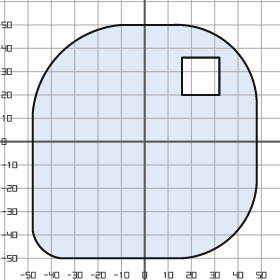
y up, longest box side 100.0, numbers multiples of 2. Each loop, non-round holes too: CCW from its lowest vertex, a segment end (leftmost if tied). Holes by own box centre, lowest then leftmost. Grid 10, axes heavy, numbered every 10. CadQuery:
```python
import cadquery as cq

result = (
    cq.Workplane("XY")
    .moveTo(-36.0, -50.0)
    .lineTo(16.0, -50.0)
    .threePointArc((38.0, -40.0), (48.0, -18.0))
    .lineTo(48.0, 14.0)
    .threePointArc((38.0, 40.0), (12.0, 50.0))
    .lineTo(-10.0, 50.0)
    .threePointArc((-36.0, 38.0), (-48.0, 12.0))
    .lineTo(-48.0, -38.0)
    .threePointArc((-44.0, -46.0), (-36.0, -50.0))
    .close()
    .moveTo(16.0, 20.0)
    .lineTo(32.0, 20.0)
    .lineTo(32.0, 36.0)
    .lineTo(16.0, 36.0)
    .close()
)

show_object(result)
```